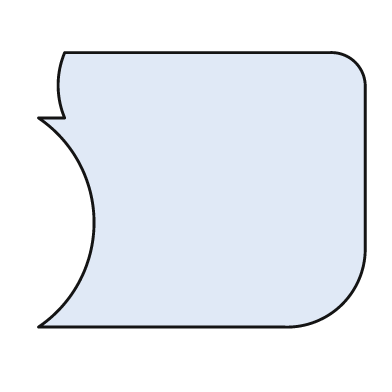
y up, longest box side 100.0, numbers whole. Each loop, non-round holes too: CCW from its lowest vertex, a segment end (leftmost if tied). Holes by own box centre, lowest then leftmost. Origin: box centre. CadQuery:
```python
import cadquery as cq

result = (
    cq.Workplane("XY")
    .moveTo(-50.0, -42.0)
    .lineTo(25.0, -42.0)
    .threePointArc((43.0, -35.0), (50.0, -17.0))
    .lineTo(50.0, 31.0)
    .threePointArc((47.0, 39.0), (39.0, 42.0))
    .lineTo(-42.0, 42.0)
    .threePointArc((-44.0, 32.0), (-42.0, 22.0))
    .lineTo(-50.0, 22.0)
    .threePointArc((-33.0, -10.0), (-50.0, -42.0))
    .close()
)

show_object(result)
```